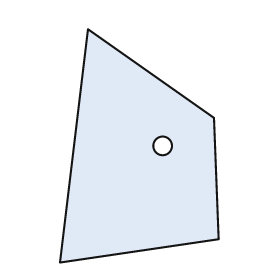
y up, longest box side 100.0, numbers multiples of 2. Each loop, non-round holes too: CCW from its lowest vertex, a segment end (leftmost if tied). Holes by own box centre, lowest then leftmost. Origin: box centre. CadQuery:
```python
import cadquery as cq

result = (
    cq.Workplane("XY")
    .moveTo(-34.0, -50.0)
    .lineTo(34.0, -40.0)
    .lineTo(32.0, 12.0)
    .lineTo(-22.0, 50.0)
    .close()
    .moveTo(10.0, 0.0)
    .circle(4.0)
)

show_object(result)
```